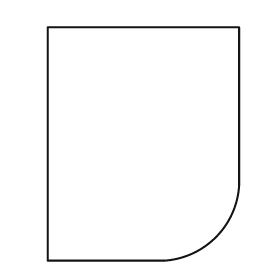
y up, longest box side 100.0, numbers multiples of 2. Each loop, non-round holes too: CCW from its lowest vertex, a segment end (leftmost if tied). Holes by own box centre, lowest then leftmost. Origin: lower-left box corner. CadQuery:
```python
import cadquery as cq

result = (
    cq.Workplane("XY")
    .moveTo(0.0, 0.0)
    .lineTo(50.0, 0.0)
    .threePointArc((72.0, 10.0), (82.0, 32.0))
    .lineTo(82.0, 100.0)
    .lineTo(0.0, 100.0)
    .close()
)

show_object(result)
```